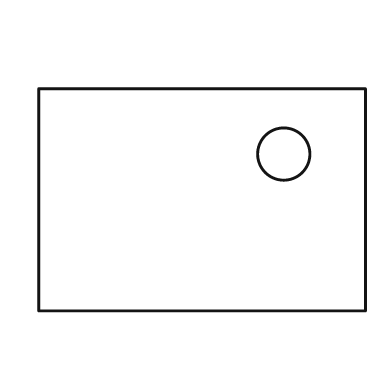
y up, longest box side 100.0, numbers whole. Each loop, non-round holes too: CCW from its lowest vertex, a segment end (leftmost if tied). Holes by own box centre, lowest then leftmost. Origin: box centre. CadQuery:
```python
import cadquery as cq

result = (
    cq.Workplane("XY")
    .moveTo(-50.0, -34.0)
    .lineTo(50.0, -34.0)
    .lineTo(50.0, 34.0)
    .lineTo(-50.0, 34.0)
    .close()
    .moveTo(25.0, 14.0)
    .circle(8.0)
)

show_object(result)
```